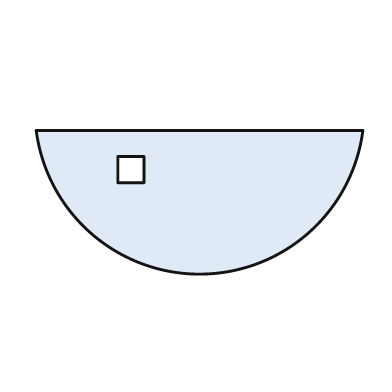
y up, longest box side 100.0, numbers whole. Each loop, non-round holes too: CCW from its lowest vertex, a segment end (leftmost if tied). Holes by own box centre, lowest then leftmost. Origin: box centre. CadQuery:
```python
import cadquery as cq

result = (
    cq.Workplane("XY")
    .moveTo(-50.0, 22.0)
    .threePointArc((0.0, -22.0), (50.0, 22.0))
    .close()
    .moveTo(-25.0, 6.0)
    .lineTo(-17.0, 6.0)
    .lineTo(-17.0, 14.0)
    .lineTo(-25.0, 14.0)
    .close()
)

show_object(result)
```